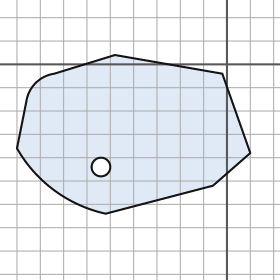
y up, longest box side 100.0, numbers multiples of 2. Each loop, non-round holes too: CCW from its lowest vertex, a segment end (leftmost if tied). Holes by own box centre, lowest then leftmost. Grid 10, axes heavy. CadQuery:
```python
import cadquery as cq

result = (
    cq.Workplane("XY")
    .moveTo(-52.0, -64.0)
    .lineTo(-6.0, -52.0)
    .lineTo(10.0, -38.0)
    .lineTo(-2.0, -4.0)
    .lineTo(-48.0, 4.0)
    .lineTo(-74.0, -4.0)
    .threePointArc((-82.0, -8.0), (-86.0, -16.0))
    .lineTo(-90.0, -36.0)
    .threePointArc((-74.0, -54.0), (-52.0, -64.0))
    .close()
    .moveTo(-54.0, -44.0)
    .circle(4.0)
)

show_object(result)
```